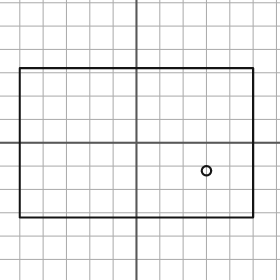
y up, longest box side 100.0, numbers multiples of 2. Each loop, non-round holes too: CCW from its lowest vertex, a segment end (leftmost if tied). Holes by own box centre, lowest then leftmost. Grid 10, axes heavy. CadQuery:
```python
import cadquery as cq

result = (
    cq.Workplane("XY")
    .moveTo(-50.0, -32.0)
    .lineTo(50.0, -32.0)
    .lineTo(50.0, 32.0)
    .lineTo(-50.0, 32.0)
    .close()
    .moveTo(30.0, -12.0)
    .circle(2.0)
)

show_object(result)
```